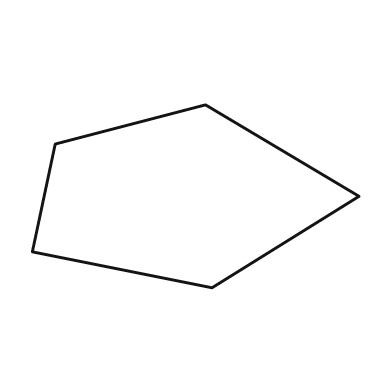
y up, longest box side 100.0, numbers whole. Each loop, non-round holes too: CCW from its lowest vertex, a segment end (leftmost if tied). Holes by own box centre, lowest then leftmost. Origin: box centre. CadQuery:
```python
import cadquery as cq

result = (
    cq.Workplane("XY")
    .moveTo(5.0, -28.0)
    .lineTo(50.0, 0.0)
    .lineTo(3.0, 28.0)
    .lineTo(-43.0, 16.0)
    .lineTo(-50.0, -17.0)
    .close()
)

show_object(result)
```